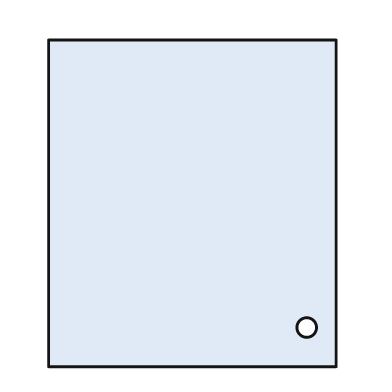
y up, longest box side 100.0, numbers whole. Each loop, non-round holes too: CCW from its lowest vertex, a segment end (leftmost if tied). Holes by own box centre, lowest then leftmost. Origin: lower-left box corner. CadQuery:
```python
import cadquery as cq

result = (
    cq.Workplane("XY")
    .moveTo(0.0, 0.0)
    .lineTo(88.0, 0.0)
    .lineTo(88.0, 100.0)
    .lineTo(0.0, 100.0)
    .close()
    .moveTo(79.0, 12.0)
    .circle(3.0)
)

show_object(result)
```